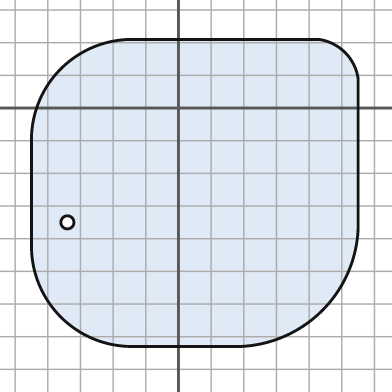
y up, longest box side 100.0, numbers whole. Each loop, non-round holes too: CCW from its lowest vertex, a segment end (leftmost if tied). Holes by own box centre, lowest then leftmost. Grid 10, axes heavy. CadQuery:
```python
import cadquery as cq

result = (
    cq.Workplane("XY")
    .moveTo(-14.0, -73.0)
    .lineTo(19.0, -73.0)
    .threePointArc((44.0, -62.0), (55.0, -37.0))
    .lineTo(55.0, 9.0)
    .threePointArc((51.0, 17.0), (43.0, 21.0))
    .lineTo(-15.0, 21.0)
    .threePointArc((-36.0, 12.0), (-45.0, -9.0))
    .lineTo(-45.0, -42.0)
    .threePointArc((-36.0, -64.0), (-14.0, -73.0))
    .close()
    .moveTo(-34.0, -35.0)
    .circle(2.0)
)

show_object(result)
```